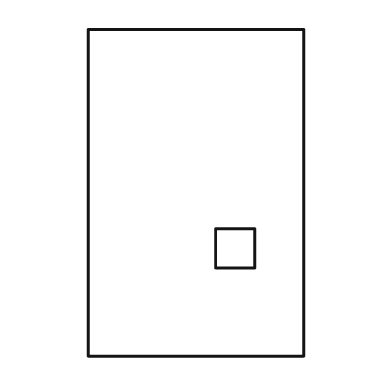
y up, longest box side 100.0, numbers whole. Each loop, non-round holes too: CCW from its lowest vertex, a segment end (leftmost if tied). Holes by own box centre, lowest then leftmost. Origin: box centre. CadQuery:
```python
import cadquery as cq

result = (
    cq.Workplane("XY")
    .moveTo(-33.0, -50.0)
    .lineTo(33.0, -50.0)
    .lineTo(33.0, 50.0)
    .lineTo(-33.0, 50.0)
    .close()
    .moveTo(6.0, -23.0)
    .lineTo(18.0, -23.0)
    .lineTo(18.0, -11.0)
    .lineTo(6.0, -11.0)
    .close()
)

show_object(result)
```